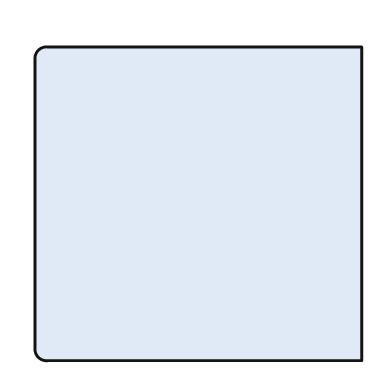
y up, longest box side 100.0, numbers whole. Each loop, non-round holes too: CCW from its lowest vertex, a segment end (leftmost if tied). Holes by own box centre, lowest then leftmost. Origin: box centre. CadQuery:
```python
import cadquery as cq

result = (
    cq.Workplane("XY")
    .moveTo(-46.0, -48.0)
    .lineTo(50.0, -48.0)
    .lineTo(50.0, 48.0)
    .lineTo(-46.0, 48.0)
    .threePointArc((-49.0, 47.0), (-50.0, 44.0))
    .lineTo(-50.0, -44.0)
    .threePointArc((-49.0, -47.0), (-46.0, -48.0))
    .close()
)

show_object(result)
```